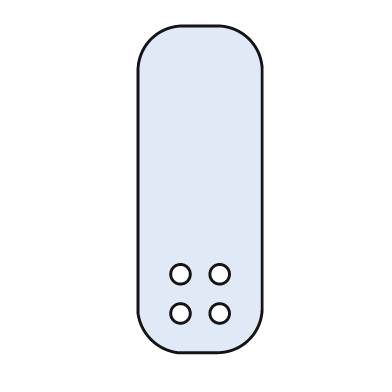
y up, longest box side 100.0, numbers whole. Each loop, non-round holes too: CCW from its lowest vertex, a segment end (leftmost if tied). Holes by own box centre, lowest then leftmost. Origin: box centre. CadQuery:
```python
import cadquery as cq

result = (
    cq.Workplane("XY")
    .moveTo(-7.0, -50.0)
    .lineTo(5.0, -50.0)
    .threePointArc((15.0, -46.0), (19.0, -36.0))
    .lineTo(19.0, 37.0)
    .threePointArc((15.0, 46.0), (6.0, 50.0))
    .lineTo(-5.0, 50.0)
    .threePointArc((-15.0, 46.0), (-19.0, 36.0))
    .lineTo(-19.0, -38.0)
    .threePointArc((-15.0, -46.0), (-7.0, -50.0))
    .close()
    .moveTo(-6.0, -38.0)
    .circle(3.0)
    .moveTo(6.0, -38.0)
    .circle(3.0)
    .moveTo(-6.0, -26.0)
    .circle(3.0)
    .moveTo(6.0, -26.0)
    .circle(3.0)
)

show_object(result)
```